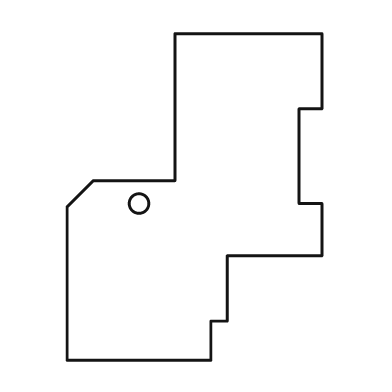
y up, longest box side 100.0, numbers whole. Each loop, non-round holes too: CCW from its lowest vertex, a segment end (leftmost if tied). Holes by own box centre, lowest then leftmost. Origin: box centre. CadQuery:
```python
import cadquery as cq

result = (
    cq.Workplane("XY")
    .moveTo(-39.0, -50.0)
    .lineTo(5.0, -50.0)
    .lineTo(5.0, -38.0)
    .lineTo(10.0, -38.0)
    .lineTo(10.0, -18.0)
    .lineTo(39.0, -18.0)
    .lineTo(39.0, -2.0)
    .lineTo(32.0, -2.0)
    .lineTo(32.0, 27.0)
    .lineTo(39.0, 27.0)
    .lineTo(39.0, 50.0)
    .lineTo(-6.0, 50.0)
    .lineTo(-6.0, 5.0)
    .lineTo(-31.0, 5.0)
    .lineTo(-39.0, -3.0)
    .close()
    .moveTo(-17.0, -2.0)
    .circle(3.0)
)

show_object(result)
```